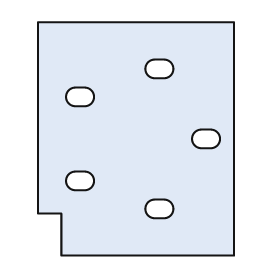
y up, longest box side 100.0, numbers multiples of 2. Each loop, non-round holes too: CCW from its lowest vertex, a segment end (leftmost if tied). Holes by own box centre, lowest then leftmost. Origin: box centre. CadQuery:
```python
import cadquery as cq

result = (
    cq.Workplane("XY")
    .moveTo(-32.0, -50.0)
    .lineTo(42.0, -50.0)
    .lineTo(42.0, 50.0)
    .lineTo(-42.0, 50.0)
    .lineTo(-42.0, -32.0)
    .lineTo(-32.0, -32.0)
    .close()
    .moveTo(8.0, -34.0)
    .lineTo(12.0, -34.0)
    .threePointArc((16.0, -30.0), (12.0, -26.0))
    .lineTo(8.0, -26.0)
    .threePointArc((4.0, -30.0), (8.0, -34.0))
    .close()
    .moveTo(-26.0, -22.0)
    .lineTo(-22.0, -22.0)
    .threePointArc((-18.0, -18.0), (-22.0, -14.0))
    .lineTo(-26.0, -14.0)
    .threePointArc((-30.0, -18.0), (-26.0, -22.0))
    .close()
    .moveTo(28.0, -4.0)
    .lineTo(32.0, -4.0)
    .threePointArc((36.0, 0.0), (32.0, 4.0))
    .lineTo(28.0, 4.0)
    .threePointArc((24.0, 0.0), (28.0, -4.0))
    .close()
    .moveTo(-26.0, 14.0)
    .lineTo(-22.0, 14.0)
    .threePointArc((-18.0, 18.0), (-22.0, 22.0))
    .lineTo(-26.0, 22.0)
    .threePointArc((-30.0, 18.0), (-26.0, 14.0))
    .close()
    .moveTo(8.0, 26.0)
    .lineTo(12.0, 26.0)
    .threePointArc((16.0, 30.0), (12.0, 34.0))
    .lineTo(8.0, 34.0)
    .threePointArc((4.0, 30.0), (8.0, 26.0))
    .close()
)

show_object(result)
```